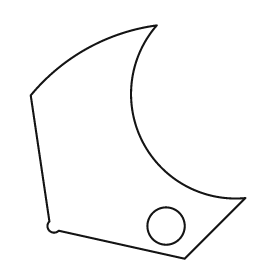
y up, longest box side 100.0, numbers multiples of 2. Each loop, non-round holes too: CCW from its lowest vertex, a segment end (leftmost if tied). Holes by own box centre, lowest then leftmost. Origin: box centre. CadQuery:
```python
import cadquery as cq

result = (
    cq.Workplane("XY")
    .moveTo(20.0, -50.0)
    .lineTo(46.0, -24.0)
    .threePointArc((2.0, 0.0), (8.0, 50.0))
    .threePointArc((-22.0, 40.0), (-46.0, 20.0))
    .lineTo(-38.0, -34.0)
    .threePointArc((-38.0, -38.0), (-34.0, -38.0))
    .close()
    .moveTo(12.0, -36.0)
    .circle(8.0)
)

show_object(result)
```